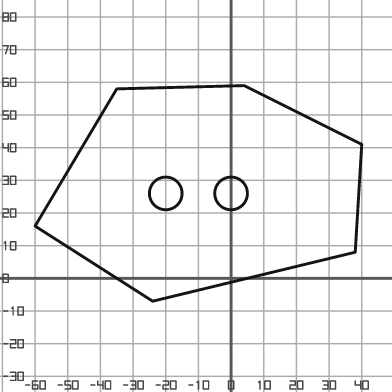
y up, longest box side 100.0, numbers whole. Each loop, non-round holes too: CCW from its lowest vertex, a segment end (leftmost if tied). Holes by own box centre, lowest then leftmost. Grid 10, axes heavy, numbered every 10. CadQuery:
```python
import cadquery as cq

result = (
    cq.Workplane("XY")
    .moveTo(-24.0, -7.0)
    .lineTo(38.0, 8.0)
    .lineTo(40.0, 41.0)
    .lineTo(4.0, 59.0)
    .lineTo(-35.0, 58.0)
    .lineTo(-60.0, 16.0)
    .close()
    .moveTo(-20.0, 26.0)
    .circle(5.0)
    .moveTo(0.0, 26.0)
    .circle(5.0)
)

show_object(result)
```